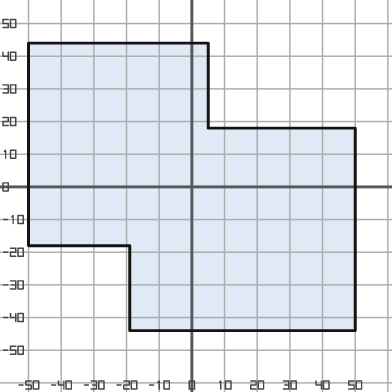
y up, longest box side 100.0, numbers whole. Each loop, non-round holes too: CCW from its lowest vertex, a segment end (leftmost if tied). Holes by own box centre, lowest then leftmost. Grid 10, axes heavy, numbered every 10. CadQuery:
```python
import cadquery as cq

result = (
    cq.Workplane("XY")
    .moveTo(-19.0, -44.0)
    .lineTo(50.0, -44.0)
    .lineTo(50.0, 18.0)
    .lineTo(5.0, 18.0)
    .lineTo(5.0, 44.0)
    .lineTo(-50.0, 44.0)
    .lineTo(-50.0, -18.0)
    .lineTo(-19.0, -18.0)
    .close()
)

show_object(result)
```